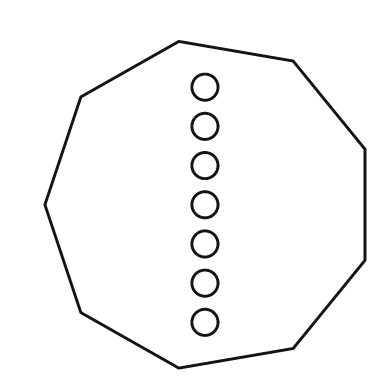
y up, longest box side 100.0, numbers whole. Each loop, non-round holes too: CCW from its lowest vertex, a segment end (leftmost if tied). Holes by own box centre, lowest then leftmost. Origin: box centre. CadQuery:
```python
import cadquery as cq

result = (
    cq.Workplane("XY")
    .moveTo(-8.0, -50.0)
    .lineTo(27.0, -44.0)
    .lineTo(49.0, -17.0)
    .lineTo(49.0, 17.0)
    .lineTo(27.0, 44.0)
    .lineTo(-8.0, 50.0)
    .lineTo(-38.0, 33.0)
    .lineTo(-49.0, 0.0)
    .lineTo(-38.0, -33.0)
    .close()
    .moveTo(0.0, -36.0)
    .circle(4.0)
    .moveTo(0.0, -24.0)
    .circle(4.0)
    .moveTo(0.0, -12.0)
    .circle(4.0)
    .moveTo(0.0, 0.0)
    .circle(4.0)
    .moveTo(0.0, 12.0)
    .circle(4.0)
    .moveTo(0.0, 24.0)
    .circle(4.0)
    .moveTo(0.0, 36.0)
    .circle(4.0)
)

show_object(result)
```